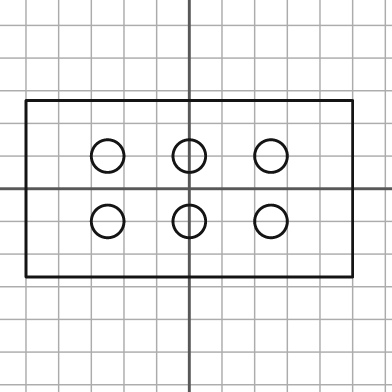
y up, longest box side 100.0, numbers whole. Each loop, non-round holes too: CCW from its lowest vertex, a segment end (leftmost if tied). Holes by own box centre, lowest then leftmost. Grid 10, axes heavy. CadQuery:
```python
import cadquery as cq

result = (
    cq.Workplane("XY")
    .moveTo(-50.0, -27.0)
    .lineTo(50.0, -27.0)
    .lineTo(50.0, 27.0)
    .lineTo(-50.0, 27.0)
    .close()
    .moveTo(-25.0, -10.0)
    .circle(5.0)
    .moveTo(0.0, -10.0)
    .circle(5.0)
    .moveTo(25.0, -10.0)
    .circle(5.0)
    .moveTo(-25.0, 10.0)
    .circle(5.0)
    .moveTo(0.0, 10.0)
    .circle(5.0)
    .moveTo(25.0, 10.0)
    .circle(5.0)
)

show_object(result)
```